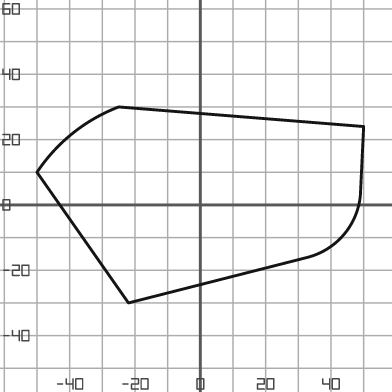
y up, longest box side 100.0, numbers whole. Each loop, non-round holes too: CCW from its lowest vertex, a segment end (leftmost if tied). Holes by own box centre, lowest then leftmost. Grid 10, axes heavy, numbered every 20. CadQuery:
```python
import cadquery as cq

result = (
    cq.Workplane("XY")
    .moveTo(-22.0, -30.0)
    .lineTo(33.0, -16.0)
    .threePointArc((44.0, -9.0), (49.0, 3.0))
    .lineTo(50.0, 24.0)
    .lineTo(-25.0, 30.0)
    .threePointArc((-39.0, 22.0), (-50.0, 10.0))
    .close()
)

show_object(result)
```